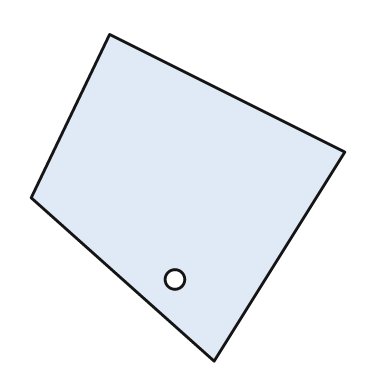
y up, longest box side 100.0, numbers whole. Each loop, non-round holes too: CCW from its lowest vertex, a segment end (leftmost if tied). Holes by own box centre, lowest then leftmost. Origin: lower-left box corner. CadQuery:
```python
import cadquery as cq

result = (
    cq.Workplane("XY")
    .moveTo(56.0, 0.0)
    .lineTo(96.0, 64.0)
    .lineTo(24.0, 100.0)
    .lineTo(0.0, 50.0)
    .close()
    .moveTo(44.0, 25.0)
    .circle(3.0)
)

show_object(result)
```